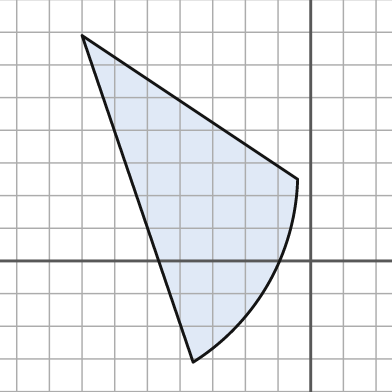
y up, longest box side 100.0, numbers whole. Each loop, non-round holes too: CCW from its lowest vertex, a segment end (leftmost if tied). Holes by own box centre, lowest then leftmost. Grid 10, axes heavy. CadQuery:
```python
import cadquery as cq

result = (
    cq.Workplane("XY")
    .moveTo(-36.0, -31.0)
    .threePointArc((-13.0, -7.0), (-4.0, 25.0))
    .lineTo(-70.0, 69.0)
    .close()
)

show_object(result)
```